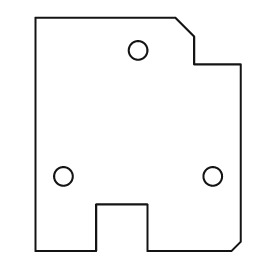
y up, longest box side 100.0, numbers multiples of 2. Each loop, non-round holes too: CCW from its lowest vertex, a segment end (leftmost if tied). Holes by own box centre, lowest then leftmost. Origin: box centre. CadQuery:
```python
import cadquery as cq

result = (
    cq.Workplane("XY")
    .moveTo(-44.0, -50.0)
    .lineTo(-18.0, -50.0)
    .lineTo(-18.0, -30.0)
    .lineTo(4.0, -30.0)
    .lineTo(4.0, -50.0)
    .lineTo(40.0, -50.0)
    .lineTo(44.0, -46.0)
    .lineTo(44.0, 30.0)
    .lineTo(24.0, 30.0)
    .lineTo(24.0, 42.0)
    .lineTo(16.0, 50.0)
    .lineTo(-44.0, 50.0)
    .close()
    .moveTo(-32.0, -18.0)
    .circle(4.0)
    .moveTo(32.0, -18.0)
    .circle(4.0)
    .moveTo(0.0, 36.0)
    .circle(4.0)
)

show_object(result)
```